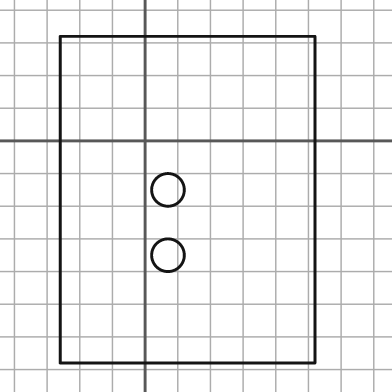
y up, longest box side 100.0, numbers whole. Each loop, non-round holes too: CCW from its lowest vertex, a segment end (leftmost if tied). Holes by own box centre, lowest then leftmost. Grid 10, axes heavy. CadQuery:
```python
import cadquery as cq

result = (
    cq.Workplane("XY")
    .moveTo(-26.0, -68.0)
    .lineTo(52.0, -68.0)
    .lineTo(52.0, 32.0)
    .lineTo(-26.0, 32.0)
    .close()
    .moveTo(7.0, -35.0)
    .circle(5.0)
    .moveTo(7.0, -15.0)
    .circle(5.0)
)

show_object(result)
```